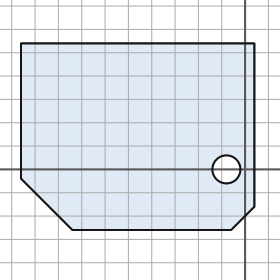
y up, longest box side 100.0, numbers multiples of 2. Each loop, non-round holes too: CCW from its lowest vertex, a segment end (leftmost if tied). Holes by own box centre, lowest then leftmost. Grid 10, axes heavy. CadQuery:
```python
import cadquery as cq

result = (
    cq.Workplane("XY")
    .moveTo(-74.0, -26.0)
    .lineTo(-6.0, -26.0)
    .lineTo(4.0, -16.0)
    .lineTo(4.0, 54.0)
    .lineTo(-96.0, 54.0)
    .lineTo(-96.0, -4.0)
    .close()
    .moveTo(-8.0, 0.0)
    .circle(6.0)
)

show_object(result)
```